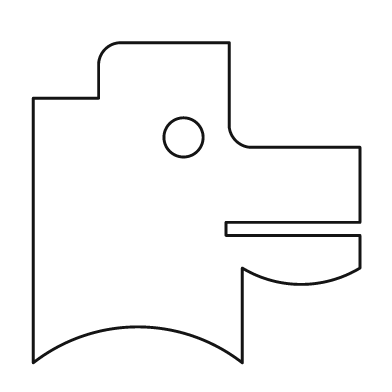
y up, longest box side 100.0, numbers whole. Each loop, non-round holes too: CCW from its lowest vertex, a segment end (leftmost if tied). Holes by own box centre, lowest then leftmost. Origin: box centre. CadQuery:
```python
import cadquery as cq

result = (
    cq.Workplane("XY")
    .moveTo(-50.0, -49.0)
    .threePointArc((-18.0, -38.0), (14.0, -49.0))
    .lineTo(14.0, -20.0)
    .threePointArc((32.0, -25.0), (50.0, -20.0))
    .lineTo(50.0, -10.0)
    .lineTo(9.0, -10.0)
    .lineTo(9.0, -6.0)
    .lineTo(50.0, -6.0)
    .lineTo(50.0, 17.0)
    .lineTo(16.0, 17.0)
    .threePointArc((12.0, 19.0), (10.0, 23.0))
    .lineTo(10.0, 49.0)
    .lineTo(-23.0, 49.0)
    .threePointArc((-28.0, 47.0), (-30.0, 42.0))
    .lineTo(-30.0, 32.0)
    .lineTo(-50.0, 32.0)
    .close()
    .moveTo(-4.0, 20.0)
    .circle(6.0)
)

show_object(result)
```